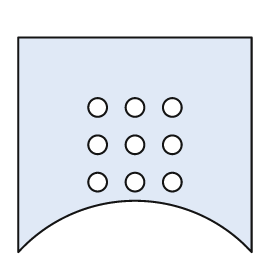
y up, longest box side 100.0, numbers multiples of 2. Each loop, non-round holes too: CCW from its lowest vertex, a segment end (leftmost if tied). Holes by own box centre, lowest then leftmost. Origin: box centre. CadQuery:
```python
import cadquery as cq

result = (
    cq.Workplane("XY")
    .moveTo(-50.0, -46.0)
    .threePointArc((0.0, -24.0), (50.0, -46.0))
    .lineTo(50.0, 46.0)
    .lineTo(-50.0, 46.0)
    .close()
    .moveTo(-16.0, -16.0)
    .circle(4.0)
    .moveTo(0.0, -16.0)
    .circle(4.0)
    .moveTo(16.0, -16.0)
    .circle(4.0)
    .moveTo(-16.0, 0.0)
    .circle(4.0)
    .moveTo(0.0, 0.0)
    .circle(4.0)
    .moveTo(16.0, 0.0)
    .circle(4.0)
    .moveTo(-16.0, 16.0)
    .circle(4.0)
    .moveTo(0.0, 16.0)
    .circle(4.0)
    .moveTo(16.0, 16.0)
    .circle(4.0)
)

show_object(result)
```